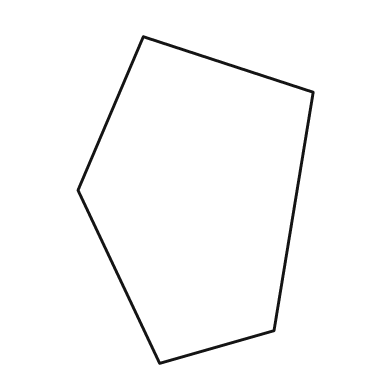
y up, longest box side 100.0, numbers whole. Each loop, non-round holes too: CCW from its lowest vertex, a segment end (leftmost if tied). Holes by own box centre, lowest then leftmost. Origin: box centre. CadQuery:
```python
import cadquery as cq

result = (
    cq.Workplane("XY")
    .moveTo(-11.0, -50.0)
    .lineTo(24.0, -40.0)
    .lineTo(36.0, 33.0)
    .lineTo(-16.0, 50.0)
    .lineTo(-36.0, 3.0)
    .close()
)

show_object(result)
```